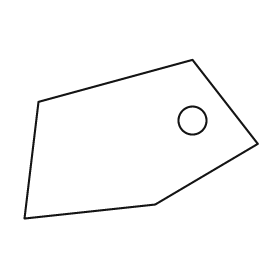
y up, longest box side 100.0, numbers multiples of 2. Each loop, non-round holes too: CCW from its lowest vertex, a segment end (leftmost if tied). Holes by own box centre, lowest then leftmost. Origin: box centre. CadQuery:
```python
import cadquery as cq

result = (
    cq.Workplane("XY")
    .moveTo(-50.0, -34.0)
    .lineTo(6.0, -28.0)
    .lineTo(50.0, -2.0)
    .lineTo(22.0, 34.0)
    .lineTo(-44.0, 16.0)
    .close()
    .moveTo(22.0, 8.0)
    .circle(6.0)
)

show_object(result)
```